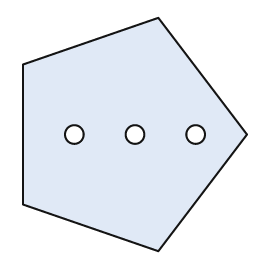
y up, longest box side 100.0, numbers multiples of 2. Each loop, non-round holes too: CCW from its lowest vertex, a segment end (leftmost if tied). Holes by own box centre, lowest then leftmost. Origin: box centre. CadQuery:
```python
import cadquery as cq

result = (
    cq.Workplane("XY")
    .moveTo(10.0, -50.0)
    .lineTo(48.0, 0.0)
    .lineTo(10.0, 50.0)
    .lineTo(-48.0, 30.0)
    .lineTo(-48.0, -30.0)
    .close()
    .moveTo(-26.0, 0.0)
    .circle(4.0)
    .moveTo(0.0, 0.0)
    .circle(4.0)
    .moveTo(26.0, 0.0)
    .circle(4.0)
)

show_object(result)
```